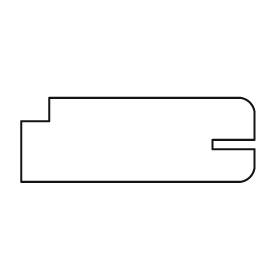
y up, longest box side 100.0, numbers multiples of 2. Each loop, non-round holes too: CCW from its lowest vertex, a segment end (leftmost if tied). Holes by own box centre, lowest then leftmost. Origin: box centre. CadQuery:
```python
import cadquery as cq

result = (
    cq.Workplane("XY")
    .moveTo(-50.0, -18.0)
    .lineTo(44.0, -18.0)
    .threePointArc((48.0, -16.0), (50.0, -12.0))
    .lineTo(50.0, -4.0)
    .lineTo(32.0, -4.0)
    .lineTo(32.0, 0.0)
    .lineTo(50.0, 0.0)
    .lineTo(50.0, 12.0)
    .threePointArc((48.0, 16.0), (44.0, 18.0))
    .lineTo(-38.0, 18.0)
    .lineTo(-38.0, 8.0)
    .lineTo(-50.0, 8.0)
    .close()
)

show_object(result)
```